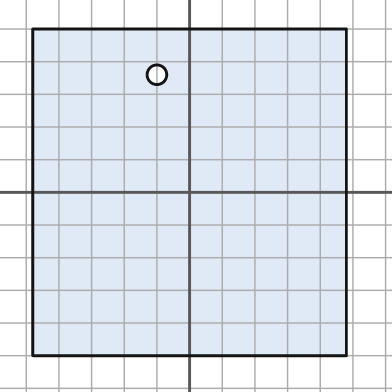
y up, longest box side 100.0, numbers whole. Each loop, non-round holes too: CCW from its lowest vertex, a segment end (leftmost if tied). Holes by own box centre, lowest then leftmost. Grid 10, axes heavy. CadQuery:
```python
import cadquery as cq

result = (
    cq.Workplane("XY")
    .moveTo(-48.0, -50.0)
    .lineTo(48.0, -50.0)
    .lineTo(48.0, 50.0)
    .lineTo(-48.0, 50.0)
    .close()
    .moveTo(-10.0, 36.0)
    .circle(3.0)
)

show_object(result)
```